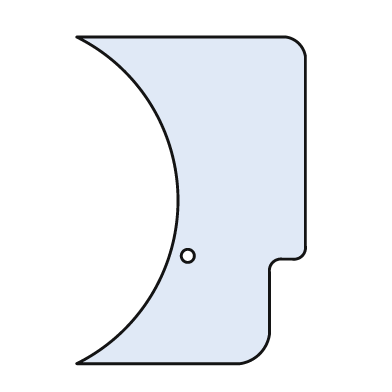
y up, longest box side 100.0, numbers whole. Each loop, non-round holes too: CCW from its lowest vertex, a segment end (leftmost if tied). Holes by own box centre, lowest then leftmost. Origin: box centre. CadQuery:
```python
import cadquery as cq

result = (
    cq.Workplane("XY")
    .moveTo(-35.0, -50.0)
    .lineTo(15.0, -50.0)
    .threePointArc((21.0, -47.0), (24.0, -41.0))
    .lineTo(24.0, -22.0)
    .threePointArc((25.0, -19.0), (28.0, -18.0))
    .lineTo(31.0, -18.0)
    .threePointArc((34.0, -17.0), (35.0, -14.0))
    .lineTo(35.0, 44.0)
    .threePointArc((33.0, 48.0), (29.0, 50.0))
    .lineTo(-35.0, 50.0)
    .threePointArc((-4.0, 0.0), (-35.0, -50.0))
    .close()
    .moveTo(-1.0, -17.0)
    .circle(2.0)
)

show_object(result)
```